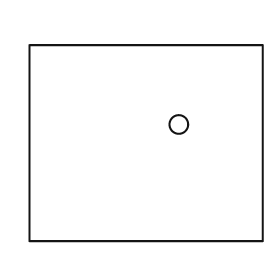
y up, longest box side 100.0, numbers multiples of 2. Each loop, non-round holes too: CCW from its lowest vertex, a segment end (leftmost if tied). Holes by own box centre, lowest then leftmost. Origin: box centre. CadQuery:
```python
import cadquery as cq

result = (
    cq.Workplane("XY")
    .moveTo(-50.0, -42.0)
    .lineTo(50.0, -42.0)
    .lineTo(50.0, 42.0)
    .lineTo(-50.0, 42.0)
    .close()
    .moveTo(14.0, 8.0)
    .circle(4.0)
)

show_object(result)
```